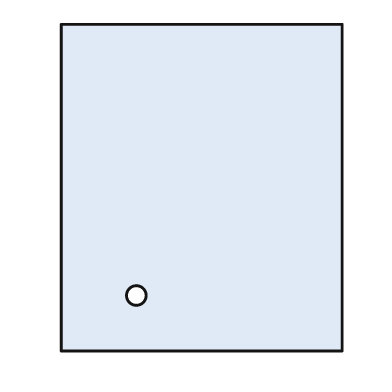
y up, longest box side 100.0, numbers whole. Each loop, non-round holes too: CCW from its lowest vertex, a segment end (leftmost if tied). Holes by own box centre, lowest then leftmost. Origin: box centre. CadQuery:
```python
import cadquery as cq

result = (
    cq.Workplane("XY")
    .moveTo(-43.0, -50.0)
    .lineTo(43.0, -50.0)
    .lineTo(43.0, 50.0)
    .lineTo(-43.0, 50.0)
    .close()
    .moveTo(-20.0, -33.0)
    .circle(3.0)
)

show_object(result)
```